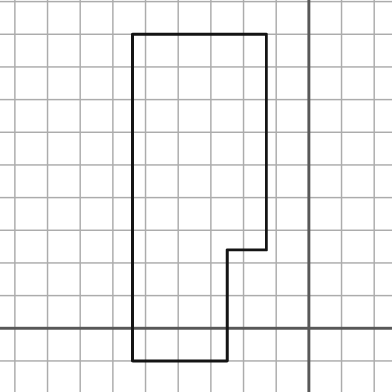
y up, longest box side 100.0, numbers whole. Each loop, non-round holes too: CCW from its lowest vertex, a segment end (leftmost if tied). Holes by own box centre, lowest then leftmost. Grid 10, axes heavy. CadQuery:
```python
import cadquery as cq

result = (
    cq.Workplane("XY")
    .moveTo(-54.0, -10.0)
    .lineTo(-25.0, -10.0)
    .lineTo(-25.0, 24.0)
    .lineTo(-13.0, 24.0)
    .lineTo(-13.0, 90.0)
    .lineTo(-54.0, 90.0)
    .close()
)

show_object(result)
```